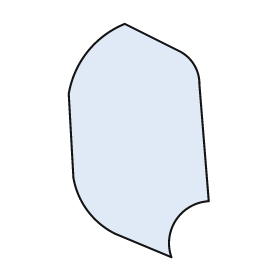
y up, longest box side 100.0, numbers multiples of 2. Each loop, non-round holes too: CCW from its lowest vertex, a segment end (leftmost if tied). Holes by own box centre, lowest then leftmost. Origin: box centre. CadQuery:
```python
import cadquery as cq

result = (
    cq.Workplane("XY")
    .moveTo(14.0, -50.0)
    .threePointArc((16.0, -34.0), (30.0, -26.0))
    .lineTo(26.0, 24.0)
    .threePointArc((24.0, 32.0), (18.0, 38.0))
    .lineTo(-6.0, 50.0)
    .threePointArc((-22.0, 38.0), (-30.0, 20.0))
    .lineTo(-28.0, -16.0)
    .threePointArc((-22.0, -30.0), (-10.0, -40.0))
    .close()
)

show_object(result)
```